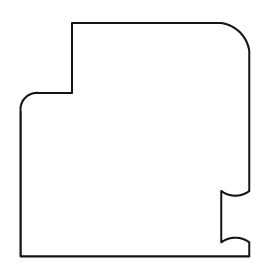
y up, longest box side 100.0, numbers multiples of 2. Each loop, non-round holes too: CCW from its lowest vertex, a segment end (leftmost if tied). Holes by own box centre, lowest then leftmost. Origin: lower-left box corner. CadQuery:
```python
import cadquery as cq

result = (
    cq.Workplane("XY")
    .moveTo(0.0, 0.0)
    .lineTo(98.0, 0.0)
    .lineTo(98.0, 6.0)
    .threePointArc((92.0, 8.0), (86.0, 6.0))
    .lineTo(86.0, 28.0)
    .threePointArc((92.0, 26.0), (98.0, 28.0))
    .lineTo(98.0, 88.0)
    .threePointArc((94.0, 96.0), (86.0, 100.0))
    .lineTo(22.0, 100.0)
    .lineTo(22.0, 70.0)
    .lineTo(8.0, 70.0)
    .threePointArc((2.0, 68.0), (0.0, 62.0))
    .close()
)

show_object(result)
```